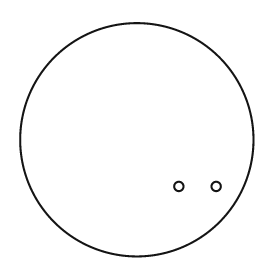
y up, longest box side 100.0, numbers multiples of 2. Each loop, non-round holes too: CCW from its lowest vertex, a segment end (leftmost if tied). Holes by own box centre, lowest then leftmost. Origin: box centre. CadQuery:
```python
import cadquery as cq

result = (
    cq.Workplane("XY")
    .moveTo(0.0, 0.0)
    .circle(50.0)
    .moveTo(18.0, -20.0)
    .circle(2.0)
    .moveTo(34.0, -20.0)
    .circle(2.0)
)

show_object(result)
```